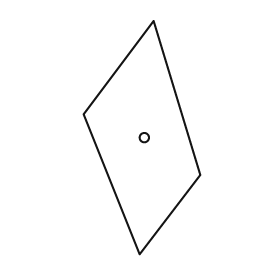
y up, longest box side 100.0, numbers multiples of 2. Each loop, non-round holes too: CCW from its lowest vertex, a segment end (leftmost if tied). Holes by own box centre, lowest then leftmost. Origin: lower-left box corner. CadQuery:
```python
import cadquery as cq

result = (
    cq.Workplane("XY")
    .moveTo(24.0, 0.0)
    .lineTo(50.0, 34.0)
    .lineTo(30.0, 100.0)
    .lineTo(0.0, 60.0)
    .close()
    .moveTo(26.0, 50.0)
    .circle(2.0)
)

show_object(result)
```